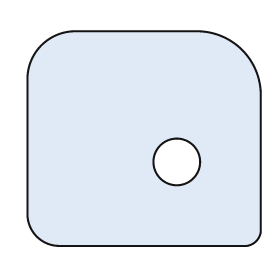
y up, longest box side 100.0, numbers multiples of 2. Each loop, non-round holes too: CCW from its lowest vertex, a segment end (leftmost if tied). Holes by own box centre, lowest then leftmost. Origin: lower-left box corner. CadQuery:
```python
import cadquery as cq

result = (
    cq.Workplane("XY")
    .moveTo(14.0, 0.0)
    .lineTo(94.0, 0.0)
    .threePointArc((98.0, 2.0), (100.0, 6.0))
    .lineTo(100.0, 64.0)
    .threePointArc((92.0, 84.0), (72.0, 92.0))
    .lineTo(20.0, 92.0)
    .threePointArc((6.0, 86.0), (0.0, 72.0))
    .lineTo(0.0, 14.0)
    .threePointArc((4.0, 4.0), (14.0, 0.0))
    .close()
    .moveTo(64.0, 36.0)
    .circle(10.0)
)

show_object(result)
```